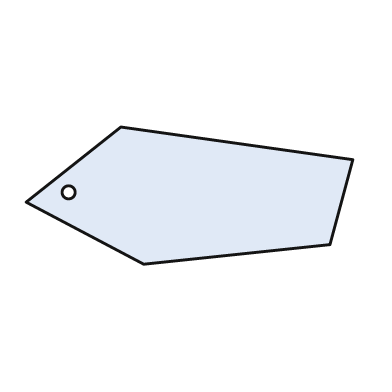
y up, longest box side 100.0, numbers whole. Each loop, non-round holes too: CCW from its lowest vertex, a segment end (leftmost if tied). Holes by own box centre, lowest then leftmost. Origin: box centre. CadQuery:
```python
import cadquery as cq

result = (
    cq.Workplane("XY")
    .moveTo(-14.0, -21.0)
    .lineTo(43.0, -15.0)
    .lineTo(50.0, 11.0)
    .lineTo(-21.0, 21.0)
    .lineTo(-50.0, -2.0)
    .close()
    .moveTo(-37.0, 1.0)
    .circle(2.0)
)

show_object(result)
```